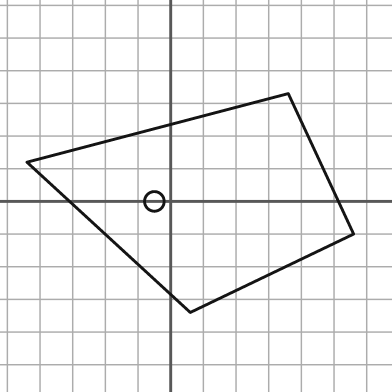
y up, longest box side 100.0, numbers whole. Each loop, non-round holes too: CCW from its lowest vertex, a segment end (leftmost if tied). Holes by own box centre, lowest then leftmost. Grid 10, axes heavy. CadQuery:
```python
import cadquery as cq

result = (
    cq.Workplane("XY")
    .moveTo(6.0, -34.0)
    .lineTo(56.0, -10.0)
    .lineTo(36.0, 33.0)
    .lineTo(-44.0, 12.0)
    .close()
    .moveTo(-5.0, 0.0)
    .circle(3.0)
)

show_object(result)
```